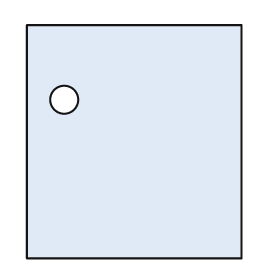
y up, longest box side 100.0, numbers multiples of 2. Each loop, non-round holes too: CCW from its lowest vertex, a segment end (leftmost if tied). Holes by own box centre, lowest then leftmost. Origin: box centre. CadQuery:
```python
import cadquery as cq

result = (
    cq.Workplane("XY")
    .moveTo(-46.0, -50.0)
    .lineTo(46.0, -50.0)
    .lineTo(46.0, 50.0)
    .lineTo(-46.0, 50.0)
    .close()
    .moveTo(-30.0, 18.0)
    .circle(6.0)
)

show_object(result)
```